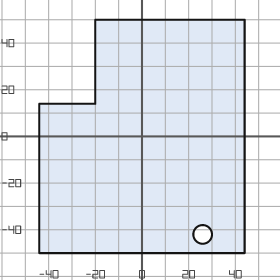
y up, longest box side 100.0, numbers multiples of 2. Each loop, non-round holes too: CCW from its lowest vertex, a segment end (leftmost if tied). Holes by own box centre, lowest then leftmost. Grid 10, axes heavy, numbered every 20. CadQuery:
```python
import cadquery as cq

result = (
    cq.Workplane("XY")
    .moveTo(-44.0, -50.0)
    .lineTo(44.0, -50.0)
    .lineTo(44.0, 50.0)
    .lineTo(-20.0, 50.0)
    .lineTo(-20.0, 14.0)
    .lineTo(-44.0, 14.0)
    .close()
    .moveTo(26.0, -42.0)
    .circle(4.0)
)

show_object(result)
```